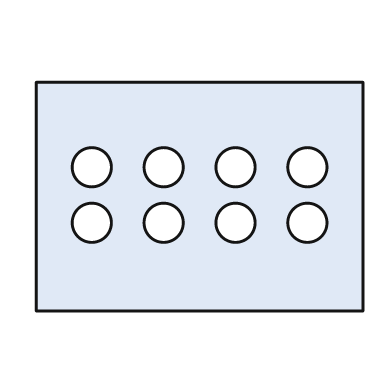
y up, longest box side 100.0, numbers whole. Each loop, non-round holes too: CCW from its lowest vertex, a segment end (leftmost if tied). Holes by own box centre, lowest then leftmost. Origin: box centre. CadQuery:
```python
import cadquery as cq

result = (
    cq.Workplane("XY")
    .moveTo(-50.0, -35.0)
    .lineTo(50.0, -35.0)
    .lineTo(50.0, 35.0)
    .lineTo(-50.0, 35.0)
    .close()
    .moveTo(-33.0, -8.0)
    .circle(6.0)
    .moveTo(-11.0, -8.0)
    .circle(6.0)
    .moveTo(11.0, -8.0)
    .circle(6.0)
    .moveTo(33.0, -8.0)
    .circle(6.0)
    .moveTo(-33.0, 9.0)
    .circle(6.0)
    .moveTo(-11.0, 9.0)
    .circle(6.0)
    .moveTo(11.0, 9.0)
    .circle(6.0)
    .moveTo(33.0, 9.0)
    .circle(6.0)
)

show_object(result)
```